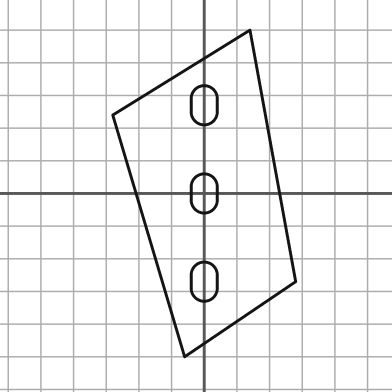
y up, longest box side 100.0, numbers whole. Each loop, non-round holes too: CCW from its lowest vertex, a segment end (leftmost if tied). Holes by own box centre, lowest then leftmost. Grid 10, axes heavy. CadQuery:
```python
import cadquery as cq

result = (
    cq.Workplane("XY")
    .moveTo(-6.0, -50.0)
    .lineTo(28.0, -27.0)
    .lineTo(14.0, 50.0)
    .lineTo(-28.0, 24.0)
    .close()
    .moveTo(-4.0, -29.0)
    .threePointArc((0.0, -33.0), (4.0, -29.0))
    .lineTo(4.0, -25.0)
    .threePointArc((0.0, -21.0), (-4.0, -25.0))
    .close()
    .moveTo(-4.0, -2.0)
    .threePointArc((0.0, -6.0), (4.0, -2.0))
    .lineTo(4.0, 2.0)
    .threePointArc((0.0, 6.0), (-4.0, 2.0))
    .close()
    .moveTo(-4.0, 25.0)
    .threePointArc((0.0, 21.0), (4.0, 25.0))
    .lineTo(4.0, 29.0)
    .threePointArc((0.0, 33.0), (-4.0, 29.0))
    .close()
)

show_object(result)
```